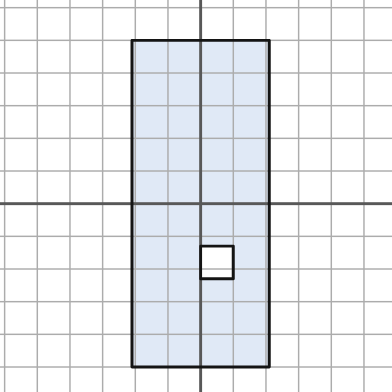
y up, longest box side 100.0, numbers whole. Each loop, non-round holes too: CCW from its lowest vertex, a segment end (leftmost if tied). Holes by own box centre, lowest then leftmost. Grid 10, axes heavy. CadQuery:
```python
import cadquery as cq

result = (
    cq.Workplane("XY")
    .moveTo(-21.0, -50.0)
    .lineTo(21.0, -50.0)
    .lineTo(21.0, 50.0)
    .lineTo(-21.0, 50.0)
    .close()
    .moveTo(0.0, -23.0)
    .lineTo(10.0, -23.0)
    .lineTo(10.0, -13.0)
    .lineTo(0.0, -13.0)
    .close()
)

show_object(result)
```